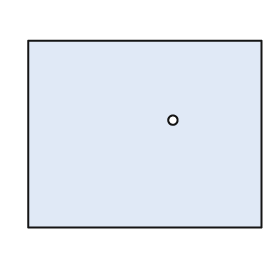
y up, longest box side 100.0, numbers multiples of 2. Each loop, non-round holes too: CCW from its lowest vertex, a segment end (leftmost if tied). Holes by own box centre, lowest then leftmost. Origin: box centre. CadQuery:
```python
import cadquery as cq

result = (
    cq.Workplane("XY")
    .moveTo(-50.0, -40.0)
    .lineTo(50.0, -40.0)
    .lineTo(50.0, 40.0)
    .lineTo(-50.0, 40.0)
    .close()
    .moveTo(12.0, 6.0)
    .circle(2.0)
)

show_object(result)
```